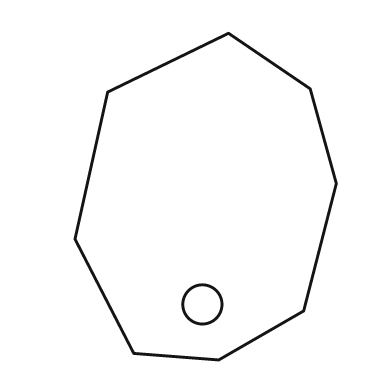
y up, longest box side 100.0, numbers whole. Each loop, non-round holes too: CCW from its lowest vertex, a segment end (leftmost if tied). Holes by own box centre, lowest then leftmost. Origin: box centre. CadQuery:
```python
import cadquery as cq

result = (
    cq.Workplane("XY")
    .moveTo(4.0, -50.0)
    .lineTo(30.0, -35.0)
    .lineTo(40.0, 4.0)
    .lineTo(32.0, 33.0)
    .lineTo(7.0, 50.0)
    .lineTo(-30.0, 32.0)
    .lineTo(-40.0, -13.0)
    .lineTo(-22.0, -48.0)
    .close()
    .moveTo(-1.0, -33.0)
    .circle(6.0)
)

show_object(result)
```